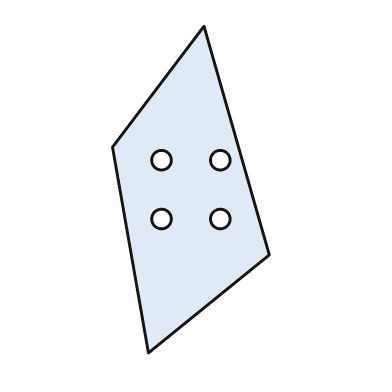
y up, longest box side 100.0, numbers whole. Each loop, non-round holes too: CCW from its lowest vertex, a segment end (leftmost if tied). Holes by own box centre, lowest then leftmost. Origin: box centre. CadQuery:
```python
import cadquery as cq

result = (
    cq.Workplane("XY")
    .moveTo(-13.0, -50.0)
    .lineTo(24.0, -20.0)
    .lineTo(4.0, 50.0)
    .lineTo(-24.0, 13.0)
    .close()
    .moveTo(-9.0, -9.0)
    .circle(3.0)
    .moveTo(9.0, -9.0)
    .circle(3.0)
    .moveTo(-9.0, 9.0)
    .circle(3.0)
    .moveTo(9.0, 9.0)
    .circle(3.0)
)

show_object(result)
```